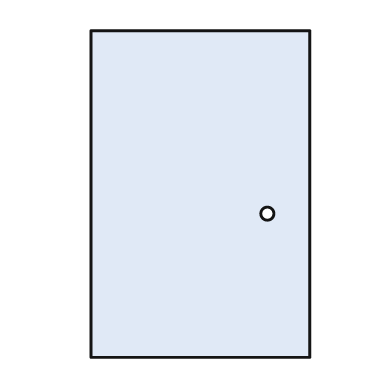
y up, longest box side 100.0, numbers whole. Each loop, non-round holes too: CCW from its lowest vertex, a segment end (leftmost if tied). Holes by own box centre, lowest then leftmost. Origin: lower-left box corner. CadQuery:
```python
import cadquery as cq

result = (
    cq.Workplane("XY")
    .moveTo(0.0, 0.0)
    .lineTo(67.0, 0.0)
    .lineTo(67.0, 100.0)
    .lineTo(0.0, 100.0)
    .close()
    .moveTo(54.0, 44.0)
    .circle(2.0)
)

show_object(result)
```